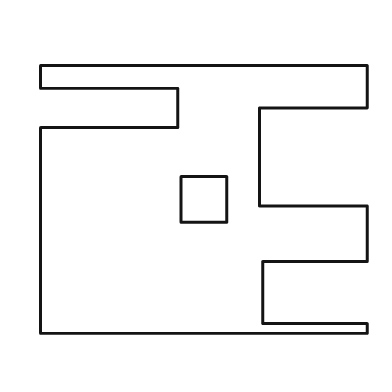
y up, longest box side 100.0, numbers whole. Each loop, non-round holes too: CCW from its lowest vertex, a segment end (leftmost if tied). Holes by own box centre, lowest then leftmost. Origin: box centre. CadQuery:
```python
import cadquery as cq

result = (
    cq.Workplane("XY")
    .moveTo(-50.0, -41.0)
    .lineTo(50.0, -41.0)
    .lineTo(50.0, -38.0)
    .lineTo(18.0, -38.0)
    .lineTo(18.0, -19.0)
    .lineTo(50.0, -19.0)
    .lineTo(50.0, -2.0)
    .lineTo(17.0, -2.0)
    .lineTo(17.0, 28.0)
    .lineTo(50.0, 28.0)
    .lineTo(50.0, 41.0)
    .lineTo(-50.0, 41.0)
    .lineTo(-50.0, 34.0)
    .lineTo(-8.0, 34.0)
    .lineTo(-8.0, 22.0)
    .lineTo(-50.0, 22.0)
    .close()
    .moveTo(-7.0, -7.0)
    .lineTo(7.0, -7.0)
    .lineTo(7.0, 7.0)
    .lineTo(-7.0, 7.0)
    .close()
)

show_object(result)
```